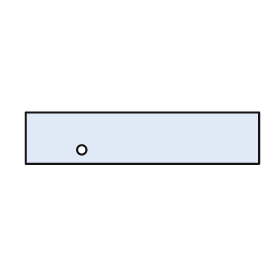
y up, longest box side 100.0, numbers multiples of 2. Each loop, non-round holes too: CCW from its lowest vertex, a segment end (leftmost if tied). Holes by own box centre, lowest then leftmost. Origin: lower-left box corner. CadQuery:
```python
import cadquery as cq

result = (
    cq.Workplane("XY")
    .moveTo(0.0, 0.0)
    .lineTo(100.0, 0.0)
    .lineTo(100.0, 22.0)
    .lineTo(0.0, 22.0)
    .close()
    .moveTo(24.0, 6.0)
    .circle(2.0)
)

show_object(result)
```